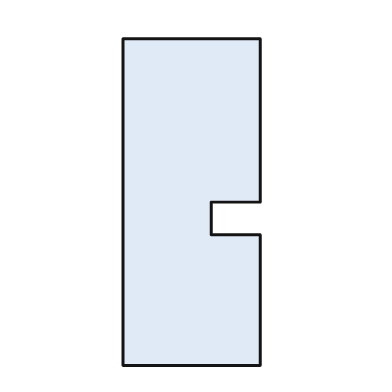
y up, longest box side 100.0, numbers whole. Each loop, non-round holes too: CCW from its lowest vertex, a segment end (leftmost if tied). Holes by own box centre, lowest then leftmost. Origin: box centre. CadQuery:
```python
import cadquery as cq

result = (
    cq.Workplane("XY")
    .moveTo(-21.0, -50.0)
    .lineTo(21.0, -50.0)
    .lineTo(21.0, -10.0)
    .lineTo(6.0, -10.0)
    .lineTo(6.0, 0.0)
    .lineTo(21.0, 0.0)
    .lineTo(21.0, 50.0)
    .lineTo(-21.0, 50.0)
    .close()
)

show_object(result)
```